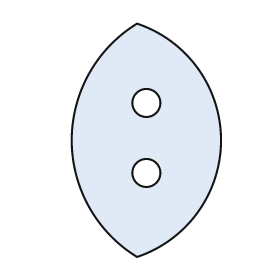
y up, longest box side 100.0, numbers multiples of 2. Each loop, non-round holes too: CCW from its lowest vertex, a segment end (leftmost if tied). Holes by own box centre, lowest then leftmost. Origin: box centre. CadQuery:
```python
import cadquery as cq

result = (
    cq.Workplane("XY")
    .moveTo(-4.0, -50.0)
    .threePointArc((32.0, 0.0), (-4.0, 50.0))
    .threePointArc((-32.0, 0.0), (-4.0, -50.0))
    .close()
    .moveTo(0.0, -14.0)
    .circle(6.0)
    .moveTo(0.0, 16.0)
    .circle(6.0)
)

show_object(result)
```